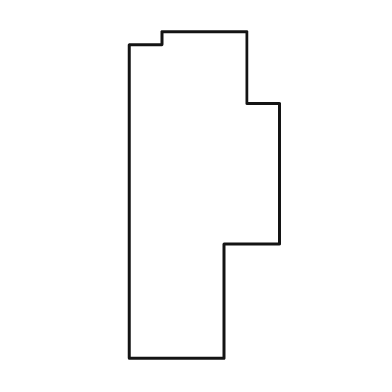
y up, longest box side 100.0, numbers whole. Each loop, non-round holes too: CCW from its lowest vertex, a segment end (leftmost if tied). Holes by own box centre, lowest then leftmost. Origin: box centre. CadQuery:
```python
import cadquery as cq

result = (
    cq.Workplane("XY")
    .moveTo(-23.0, -50.0)
    .lineTo(6.0, -50.0)
    .lineTo(6.0, -15.0)
    .lineTo(23.0, -15.0)
    .lineTo(23.0, 28.0)
    .lineTo(13.0, 28.0)
    .lineTo(13.0, 50.0)
    .lineTo(-13.0, 50.0)
    .lineTo(-13.0, 46.0)
    .lineTo(-23.0, 46.0)
    .close()
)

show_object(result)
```